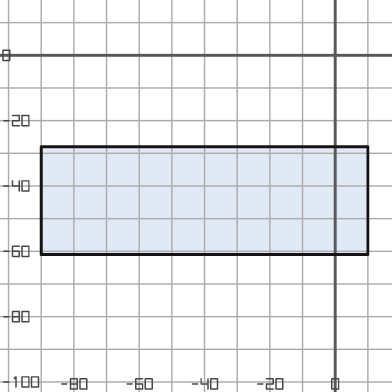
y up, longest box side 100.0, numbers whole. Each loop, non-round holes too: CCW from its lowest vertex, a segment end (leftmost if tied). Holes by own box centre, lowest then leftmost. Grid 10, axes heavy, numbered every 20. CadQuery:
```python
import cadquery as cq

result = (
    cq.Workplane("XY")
    .moveTo(-90.0, -61.0)
    .lineTo(10.0, -61.0)
    .lineTo(10.0, -28.0)
    .lineTo(-90.0, -28.0)
    .close()
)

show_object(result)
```